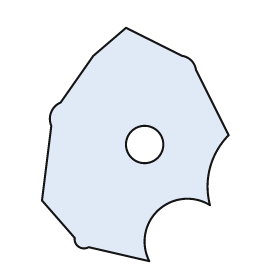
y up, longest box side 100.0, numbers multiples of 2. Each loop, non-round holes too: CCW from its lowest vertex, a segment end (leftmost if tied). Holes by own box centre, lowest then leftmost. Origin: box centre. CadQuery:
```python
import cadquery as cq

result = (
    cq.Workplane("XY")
    .moveTo(6.0, -50.0)
    .threePointArc((10.0, -28.0), (32.0, -26.0))
    .threePointArc((32.0, -10.0), (40.0, 4.0))
    .lineTo(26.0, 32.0)
    .threePointArc((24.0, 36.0), (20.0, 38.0))
    .lineTo(-4.0, 50.0)
    .lineTo(-18.0, 38.0)
    .lineTo(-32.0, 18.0)
    .threePointArc((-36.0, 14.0), (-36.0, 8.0))
    .lineTo(-40.0, -24.0)
    .lineTo(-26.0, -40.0)
    .threePointArc((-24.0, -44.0), (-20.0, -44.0))
    .close()
    .moveTo(4.0, 0.0)
    .circle(8.0)
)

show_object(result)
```